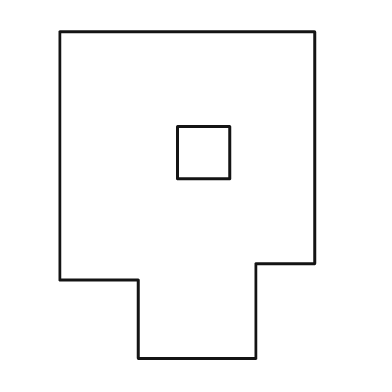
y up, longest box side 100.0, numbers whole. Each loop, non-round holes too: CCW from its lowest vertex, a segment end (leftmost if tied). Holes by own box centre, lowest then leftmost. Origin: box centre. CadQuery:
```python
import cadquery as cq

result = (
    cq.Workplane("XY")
    .moveTo(-15.0, -50.0)
    .lineTo(21.0, -50.0)
    .lineTo(21.0, -21.0)
    .lineTo(39.0, -21.0)
    .lineTo(39.0, 50.0)
    .lineTo(-39.0, 50.0)
    .lineTo(-39.0, -26.0)
    .lineTo(-15.0, -26.0)
    .close()
    .moveTo(-3.0, 5.0)
    .lineTo(13.0, 5.0)
    .lineTo(13.0, 21.0)
    .lineTo(-3.0, 21.0)
    .close()
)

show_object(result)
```